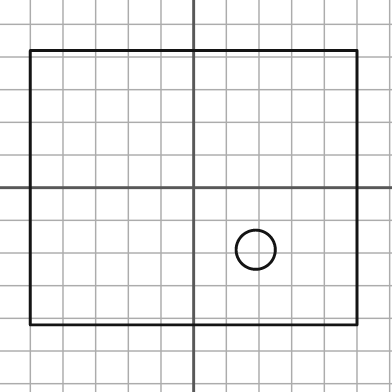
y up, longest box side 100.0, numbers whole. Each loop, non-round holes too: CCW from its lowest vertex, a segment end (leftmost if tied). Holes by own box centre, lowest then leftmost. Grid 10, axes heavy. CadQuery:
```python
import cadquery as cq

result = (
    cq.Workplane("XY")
    .moveTo(-50.0, -42.0)
    .lineTo(50.0, -42.0)
    .lineTo(50.0, 42.0)
    .lineTo(-50.0, 42.0)
    .close()
    .moveTo(19.0, -19.0)
    .circle(6.0)
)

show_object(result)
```